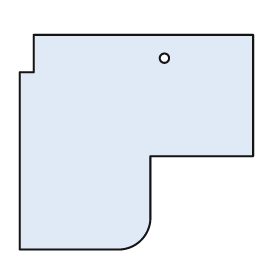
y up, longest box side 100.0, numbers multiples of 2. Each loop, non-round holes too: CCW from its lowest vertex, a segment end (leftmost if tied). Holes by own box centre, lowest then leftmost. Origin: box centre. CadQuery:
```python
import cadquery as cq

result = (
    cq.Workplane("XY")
    .moveTo(-50.0, -46.0)
    .lineTo(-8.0, -46.0)
    .threePointArc((2.0, -42.0), (6.0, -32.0))
    .lineTo(6.0, -6.0)
    .lineTo(50.0, -6.0)
    .lineTo(50.0, 46.0)
    .lineTo(-44.0, 46.0)
    .lineTo(-44.0, 30.0)
    .lineTo(-50.0, 30.0)
    .close()
    .moveTo(12.0, 36.0)
    .circle(2.0)
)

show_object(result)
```